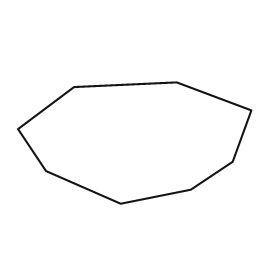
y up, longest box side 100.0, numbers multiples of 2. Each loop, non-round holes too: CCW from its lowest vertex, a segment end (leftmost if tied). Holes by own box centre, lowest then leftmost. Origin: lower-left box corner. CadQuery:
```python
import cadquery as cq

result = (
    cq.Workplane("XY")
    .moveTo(44.0, 0.0)
    .lineTo(74.0, 6.0)
    .lineTo(92.0, 18.0)
    .lineTo(100.0, 40.0)
    .lineTo(68.0, 52.0)
    .lineTo(24.0, 50.0)
    .lineTo(0.0, 32.0)
    .lineTo(12.0, 14.0)
    .close()
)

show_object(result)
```